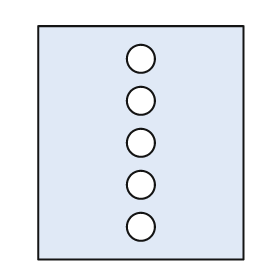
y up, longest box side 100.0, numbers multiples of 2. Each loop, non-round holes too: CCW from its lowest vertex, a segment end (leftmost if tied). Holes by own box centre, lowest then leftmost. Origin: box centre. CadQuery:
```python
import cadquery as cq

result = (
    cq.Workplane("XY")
    .moveTo(-44.0, -50.0)
    .lineTo(44.0, -50.0)
    .lineTo(44.0, 50.0)
    .lineTo(-44.0, 50.0)
    .close()
    .moveTo(0.0, -36.0)
    .circle(6.0)
    .moveTo(0.0, -18.0)
    .circle(6.0)
    .moveTo(0.0, 0.0)
    .circle(6.0)
    .moveTo(0.0, 18.0)
    .circle(6.0)
    .moveTo(0.0, 36.0)
    .circle(6.0)
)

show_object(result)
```